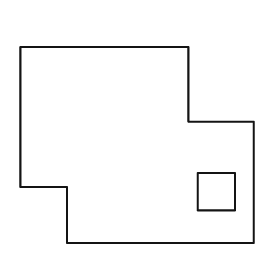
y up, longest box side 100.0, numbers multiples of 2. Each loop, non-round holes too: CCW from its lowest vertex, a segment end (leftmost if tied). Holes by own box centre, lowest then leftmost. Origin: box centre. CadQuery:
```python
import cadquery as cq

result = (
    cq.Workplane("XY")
    .moveTo(-30.0, -42.0)
    .lineTo(50.0, -42.0)
    .lineTo(50.0, 10.0)
    .lineTo(22.0, 10.0)
    .lineTo(22.0, 42.0)
    .lineTo(-50.0, 42.0)
    .lineTo(-50.0, -18.0)
    .lineTo(-30.0, -18.0)
    .close()
    .moveTo(26.0, -28.0)
    .lineTo(42.0, -28.0)
    .lineTo(42.0, -12.0)
    .lineTo(26.0, -12.0)
    .close()
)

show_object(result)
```